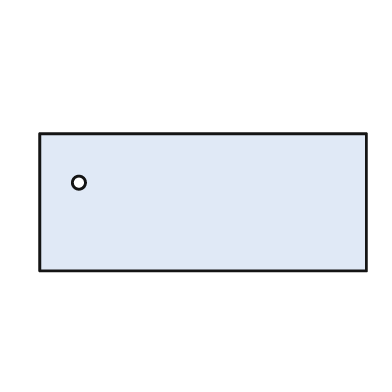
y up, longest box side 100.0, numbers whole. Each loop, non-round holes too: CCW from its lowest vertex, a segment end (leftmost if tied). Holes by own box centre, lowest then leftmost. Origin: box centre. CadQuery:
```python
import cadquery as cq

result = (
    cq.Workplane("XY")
    .moveTo(-50.0, -21.0)
    .lineTo(50.0, -21.0)
    .lineTo(50.0, 21.0)
    .lineTo(-50.0, 21.0)
    .close()
    .moveTo(-38.0, 6.0)
    .circle(2.0)
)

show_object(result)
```